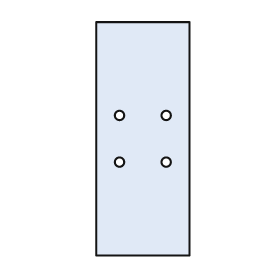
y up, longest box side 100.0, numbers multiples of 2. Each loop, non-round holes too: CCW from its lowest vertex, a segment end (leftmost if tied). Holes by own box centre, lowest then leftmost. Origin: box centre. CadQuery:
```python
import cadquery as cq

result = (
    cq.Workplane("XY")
    .moveTo(-20.0, -50.0)
    .lineTo(20.0, -50.0)
    .lineTo(20.0, 50.0)
    .lineTo(-20.0, 50.0)
    .close()
    .moveTo(-10.0, -10.0)
    .circle(2.0)
    .moveTo(10.0, -10.0)
    .circle(2.0)
    .moveTo(-10.0, 10.0)
    .circle(2.0)
    .moveTo(10.0, 10.0)
    .circle(2.0)
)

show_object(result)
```